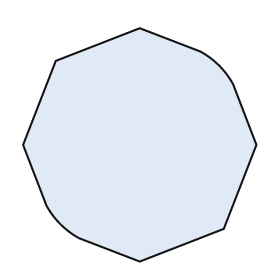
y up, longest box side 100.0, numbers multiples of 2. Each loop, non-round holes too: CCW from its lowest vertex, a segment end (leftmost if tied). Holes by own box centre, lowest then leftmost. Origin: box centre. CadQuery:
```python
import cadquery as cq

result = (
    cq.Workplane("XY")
    .moveTo(0.0, -50.0)
    .lineTo(36.0, -36.0)
    .lineTo(50.0, 0.0)
    .lineTo(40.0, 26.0)
    .threePointArc((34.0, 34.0), (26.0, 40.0))
    .lineTo(0.0, 50.0)
    .lineTo(-36.0, 36.0)
    .lineTo(-50.0, 0.0)
    .lineTo(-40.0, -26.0)
    .threePointArc((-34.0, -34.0), (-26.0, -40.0))
    .close()
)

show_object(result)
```